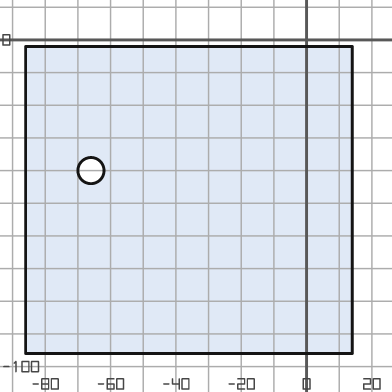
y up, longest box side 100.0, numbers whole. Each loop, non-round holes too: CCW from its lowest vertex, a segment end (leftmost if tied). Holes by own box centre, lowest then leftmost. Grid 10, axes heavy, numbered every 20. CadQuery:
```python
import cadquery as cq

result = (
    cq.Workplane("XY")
    .moveTo(-86.0, -96.0)
    .lineTo(14.0, -96.0)
    .lineTo(14.0, -2.0)
    .lineTo(-86.0, -2.0)
    .close()
    .moveTo(-66.0, -40.0)
    .circle(4.0)
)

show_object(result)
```